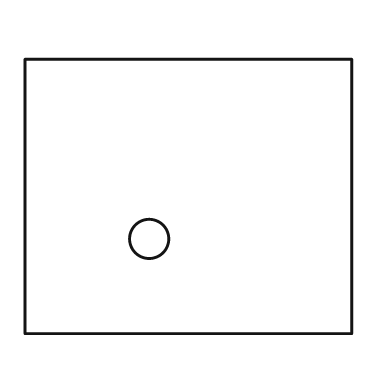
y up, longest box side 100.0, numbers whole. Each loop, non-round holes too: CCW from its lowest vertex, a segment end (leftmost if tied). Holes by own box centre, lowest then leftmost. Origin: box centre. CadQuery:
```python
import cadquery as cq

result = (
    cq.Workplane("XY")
    .moveTo(-50.0, -42.0)
    .lineTo(50.0, -42.0)
    .lineTo(50.0, 42.0)
    .lineTo(-50.0, 42.0)
    .close()
    .moveTo(-12.0, -13.0)
    .circle(6.0)
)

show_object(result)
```